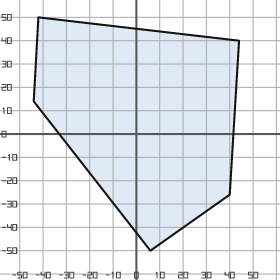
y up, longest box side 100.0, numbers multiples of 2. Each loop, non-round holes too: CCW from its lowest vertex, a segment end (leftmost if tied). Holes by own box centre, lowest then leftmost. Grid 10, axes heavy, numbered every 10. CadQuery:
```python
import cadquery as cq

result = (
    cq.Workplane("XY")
    .moveTo(6.0, -50.0)
    .lineTo(40.0, -26.0)
    .lineTo(44.0, 40.0)
    .lineTo(-42.0, 50.0)
    .lineTo(-44.0, 14.0)
    .close()
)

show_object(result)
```